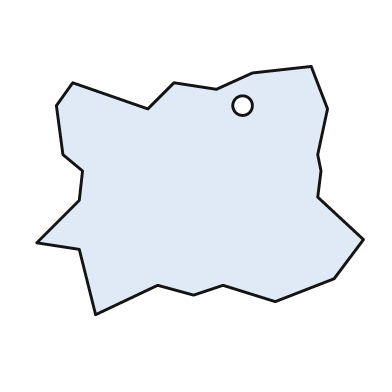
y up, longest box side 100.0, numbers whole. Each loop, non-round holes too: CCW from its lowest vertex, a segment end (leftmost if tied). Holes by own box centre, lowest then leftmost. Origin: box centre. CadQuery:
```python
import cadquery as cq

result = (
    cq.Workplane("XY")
    .moveTo(-32.0, -38.0)
    .lineTo(-13.0, -29.0)
    .lineTo(-2.0, -32.0)
    .lineTo(7.0, -29.0)
    .lineTo(23.0, -34.0)
    .lineTo(41.0, -27.0)
    .lineTo(50.0, -15.0)
    .lineTo(36.0, -2.0)
    .lineTo(37.0, 6.0)
    .lineTo(36.0, 11.0)
    .lineTo(39.0, 25.0)
    .lineTo(34.0, 38.0)
    .lineTo(16.0, 36.0)
    .lineTo(5.0, 31.0)
    .lineTo(-8.0, 33.0)
    .lineTo(-16.0, 25.0)
    .lineTo(-39.0, 33.0)
    .lineTo(-44.0, 26.0)
    .lineTo(-42.0, 11.0)
    .lineTo(-36.0, 6.0)
    .lineTo(-37.0, -3.0)
    .lineTo(-50.0, -16.0)
    .lineTo(-37.0, -18.0)
    .close()
    .moveTo(13.0, 26.0)
    .circle(3.0)
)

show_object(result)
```